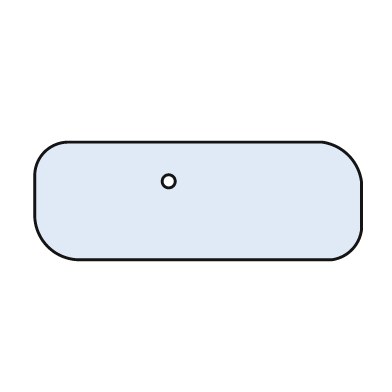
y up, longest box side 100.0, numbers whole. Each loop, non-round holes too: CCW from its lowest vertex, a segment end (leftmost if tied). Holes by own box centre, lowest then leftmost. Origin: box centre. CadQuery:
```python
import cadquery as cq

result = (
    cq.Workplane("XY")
    .moveTo(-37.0, -18.0)
    .lineTo(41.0, -18.0)
    .threePointArc((47.0, -15.0), (50.0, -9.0))
    .lineTo(50.0, 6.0)
    .threePointArc((46.0, 14.0), (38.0, 18.0))
    .lineTo(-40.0, 18.0)
    .threePointArc((-47.0, 15.0), (-50.0, 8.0))
    .lineTo(-50.0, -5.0)
    .threePointArc((-46.0, -14.0), (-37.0, -18.0))
    .close()
    .moveTo(-9.0, 6.0)
    .circle(2.0)
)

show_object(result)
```